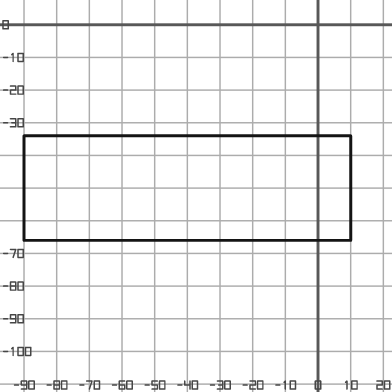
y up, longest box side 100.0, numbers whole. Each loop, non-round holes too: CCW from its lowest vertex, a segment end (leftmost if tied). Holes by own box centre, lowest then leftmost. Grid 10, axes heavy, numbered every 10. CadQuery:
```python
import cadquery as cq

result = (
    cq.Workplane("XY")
    .moveTo(-90.0, -66.0)
    .lineTo(10.0, -66.0)
    .lineTo(10.0, -34.0)
    .lineTo(-90.0, -34.0)
    .close()
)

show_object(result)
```